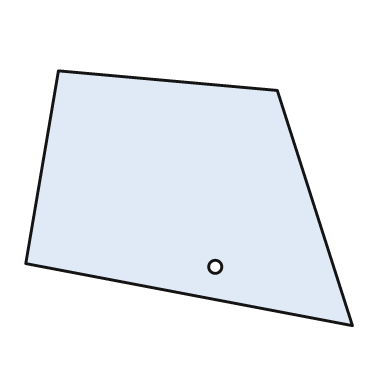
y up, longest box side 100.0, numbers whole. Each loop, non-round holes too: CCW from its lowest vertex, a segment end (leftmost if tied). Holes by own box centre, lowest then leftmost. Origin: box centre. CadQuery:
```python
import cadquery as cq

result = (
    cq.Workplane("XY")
    .moveTo(50.0, -39.0)
    .lineTo(27.0, 33.0)
    .lineTo(-40.0, 39.0)
    .lineTo(-50.0, -20.0)
    .close()
    .moveTo(8.0, -21.0)
    .circle(2.0)
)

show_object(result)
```